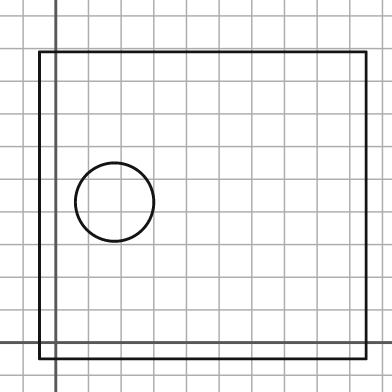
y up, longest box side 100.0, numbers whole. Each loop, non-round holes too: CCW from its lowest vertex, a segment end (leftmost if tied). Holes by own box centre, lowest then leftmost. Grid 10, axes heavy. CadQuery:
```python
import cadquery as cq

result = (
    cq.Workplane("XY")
    .moveTo(-5.0, -5.0)
    .lineTo(95.0, -5.0)
    .lineTo(95.0, 89.0)
    .lineTo(-5.0, 89.0)
    .close()
    .moveTo(18.0, 43.0)
    .circle(12.0)
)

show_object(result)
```